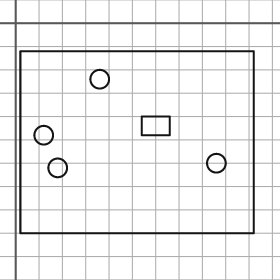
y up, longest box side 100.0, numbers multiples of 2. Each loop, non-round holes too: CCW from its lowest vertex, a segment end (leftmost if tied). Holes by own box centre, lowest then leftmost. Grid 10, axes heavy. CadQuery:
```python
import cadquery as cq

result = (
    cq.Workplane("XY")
    .moveTo(2.0, -90.0)
    .lineTo(102.0, -90.0)
    .lineTo(102.0, -12.0)
    .lineTo(2.0, -12.0)
    .close()
    .moveTo(18.0, -62.0)
    .circle(4.0)
    .moveTo(86.0, -60.0)
    .circle(4.0)
    .moveTo(12.0, -48.0)
    .circle(4.0)
    .moveTo(54.0, -48.0)
    .lineTo(66.0, -48.0)
    .lineTo(66.0, -40.0)
    .lineTo(54.0, -40.0)
    .close()
    .moveTo(36.0, -24.0)
    .circle(4.0)
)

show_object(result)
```